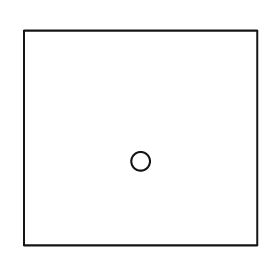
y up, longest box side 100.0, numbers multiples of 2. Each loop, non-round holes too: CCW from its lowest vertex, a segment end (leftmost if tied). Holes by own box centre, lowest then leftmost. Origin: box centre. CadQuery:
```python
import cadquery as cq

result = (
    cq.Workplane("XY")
    .moveTo(-50.0, -46.0)
    .lineTo(50.0, -46.0)
    .lineTo(50.0, 46.0)
    .lineTo(-50.0, 46.0)
    .close()
    .moveTo(0.0, -10.0)
    .circle(4.0)
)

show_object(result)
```